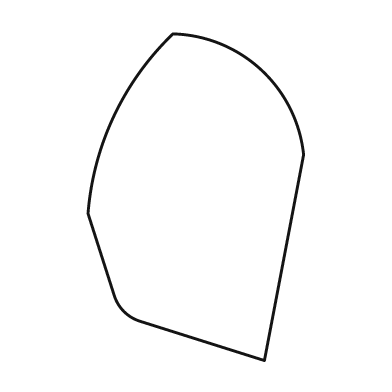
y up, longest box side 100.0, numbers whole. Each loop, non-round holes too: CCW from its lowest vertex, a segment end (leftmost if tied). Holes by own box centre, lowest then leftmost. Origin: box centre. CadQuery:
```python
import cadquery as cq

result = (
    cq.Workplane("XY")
    .moveTo(21.0, -50.0)
    .lineTo(33.0, 13.0)
    .threePointArc((20.0, 39.0), (-7.0, 50.0))
    .threePointArc((-25.0, 25.0), (-33.0, -5.0))
    .lineTo(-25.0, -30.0)
    .threePointArc((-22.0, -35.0), (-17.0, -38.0))
    .close()
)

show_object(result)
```